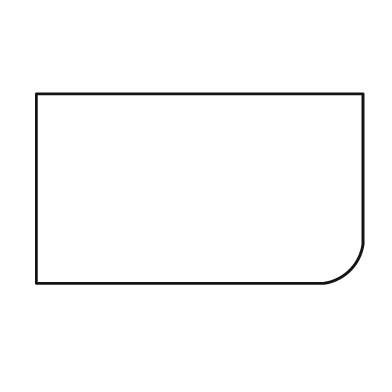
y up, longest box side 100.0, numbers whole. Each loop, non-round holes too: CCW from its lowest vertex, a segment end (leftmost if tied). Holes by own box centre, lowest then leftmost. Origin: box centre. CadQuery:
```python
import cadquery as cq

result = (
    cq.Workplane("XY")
    .moveTo(-50.0, -29.0)
    .lineTo(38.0, -29.0)
    .threePointArc((46.0, -25.0), (50.0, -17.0))
    .lineTo(50.0, 29.0)
    .lineTo(-50.0, 29.0)
    .close()
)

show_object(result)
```